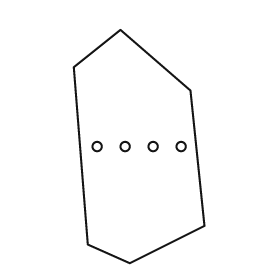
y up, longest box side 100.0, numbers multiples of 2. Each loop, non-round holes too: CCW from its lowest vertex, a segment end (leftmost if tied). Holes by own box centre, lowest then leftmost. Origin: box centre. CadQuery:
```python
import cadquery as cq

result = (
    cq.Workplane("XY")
    .moveTo(-4.0, -50.0)
    .lineTo(28.0, -34.0)
    .lineTo(22.0, 24.0)
    .lineTo(-8.0, 50.0)
    .lineTo(-28.0, 34.0)
    .lineTo(-22.0, -42.0)
    .close()
    .moveTo(-18.0, 0.0)
    .circle(2.0)
    .moveTo(-6.0, 0.0)
    .circle(2.0)
    .moveTo(6.0, 0.0)
    .circle(2.0)
    .moveTo(18.0, 0.0)
    .circle(2.0)
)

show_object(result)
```